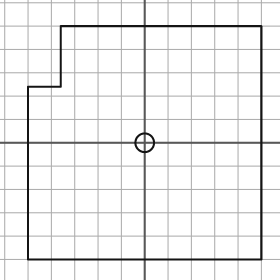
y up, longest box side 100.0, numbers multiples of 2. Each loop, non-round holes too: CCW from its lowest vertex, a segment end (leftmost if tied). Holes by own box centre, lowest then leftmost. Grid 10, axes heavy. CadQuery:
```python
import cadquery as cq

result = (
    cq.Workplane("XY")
    .moveTo(-50.0, -50.0)
    .lineTo(50.0, -50.0)
    .lineTo(50.0, 50.0)
    .lineTo(-36.0, 50.0)
    .lineTo(-36.0, 24.0)
    .lineTo(-50.0, 24.0)
    .close()
    .moveTo(0.0, 0.0)
    .circle(4.0)
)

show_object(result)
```